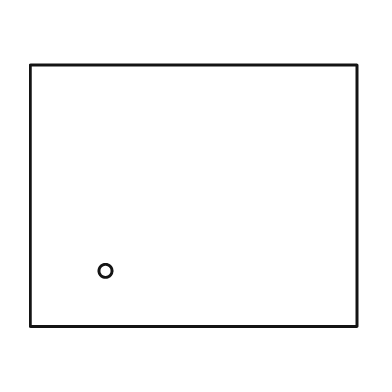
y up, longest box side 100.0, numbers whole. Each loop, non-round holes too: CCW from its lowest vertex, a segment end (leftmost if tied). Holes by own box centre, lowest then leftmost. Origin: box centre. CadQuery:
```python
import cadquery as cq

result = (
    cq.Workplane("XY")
    .moveTo(-50.0, -40.0)
    .lineTo(50.0, -40.0)
    .lineTo(50.0, 40.0)
    .lineTo(-50.0, 40.0)
    .close()
    .moveTo(-27.0, -23.0)
    .circle(2.0)
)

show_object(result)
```